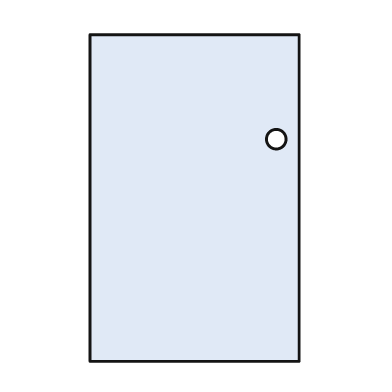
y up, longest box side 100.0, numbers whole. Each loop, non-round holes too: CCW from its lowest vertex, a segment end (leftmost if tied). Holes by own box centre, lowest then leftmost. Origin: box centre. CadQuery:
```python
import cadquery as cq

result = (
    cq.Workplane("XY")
    .moveTo(-32.0, -50.0)
    .lineTo(32.0, -50.0)
    .lineTo(32.0, 50.0)
    .lineTo(-32.0, 50.0)
    .close()
    .moveTo(25.0, 18.0)
    .circle(3.0)
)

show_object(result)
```